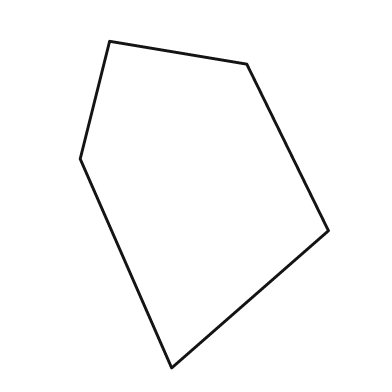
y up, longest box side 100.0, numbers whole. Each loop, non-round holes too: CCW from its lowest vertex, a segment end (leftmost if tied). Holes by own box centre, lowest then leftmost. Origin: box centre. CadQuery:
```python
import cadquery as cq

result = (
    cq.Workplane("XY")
    .moveTo(-10.0, -50.0)
    .lineTo(38.0, -8.0)
    .lineTo(13.0, 43.0)
    .lineTo(-29.0, 50.0)
    .lineTo(-38.0, 14.0)
    .close()
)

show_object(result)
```